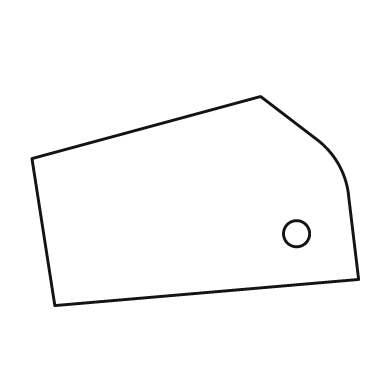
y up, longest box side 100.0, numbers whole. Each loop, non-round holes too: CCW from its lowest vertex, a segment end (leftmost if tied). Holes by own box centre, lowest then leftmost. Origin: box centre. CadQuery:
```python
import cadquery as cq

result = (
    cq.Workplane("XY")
    .moveTo(-43.0, -32.0)
    .lineTo(50.0, -24.0)
    .lineTo(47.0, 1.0)
    .threePointArc((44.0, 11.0), (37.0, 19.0))
    .lineTo(20.0, 32.0)
    .lineTo(-50.0, 13.0)
    .close()
    .moveTo(31.0, -10.0)
    .circle(4.0)
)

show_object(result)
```